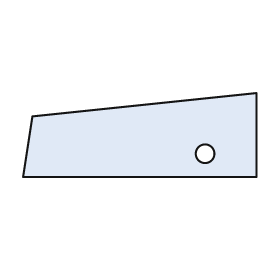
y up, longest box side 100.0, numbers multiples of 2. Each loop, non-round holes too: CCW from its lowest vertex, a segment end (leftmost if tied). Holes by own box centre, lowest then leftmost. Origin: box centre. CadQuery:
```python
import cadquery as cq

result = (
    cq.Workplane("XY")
    .moveTo(-50.0, -18.0)
    .lineTo(50.0, -18.0)
    .lineTo(50.0, 18.0)
    .lineTo(-46.0, 8.0)
    .close()
    .moveTo(28.0, -8.0)
    .circle(4.0)
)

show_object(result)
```